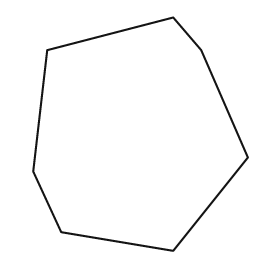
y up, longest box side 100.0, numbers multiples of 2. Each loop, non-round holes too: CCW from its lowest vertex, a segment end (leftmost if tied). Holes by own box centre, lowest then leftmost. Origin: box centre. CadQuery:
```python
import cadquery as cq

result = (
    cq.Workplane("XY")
    .moveTo(14.0, -50.0)
    .lineTo(46.0, -10.0)
    .lineTo(26.0, 36.0)
    .lineTo(14.0, 50.0)
    .lineTo(-40.0, 36.0)
    .lineTo(-46.0, -16.0)
    .lineTo(-34.0, -42.0)
    .close()
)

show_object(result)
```